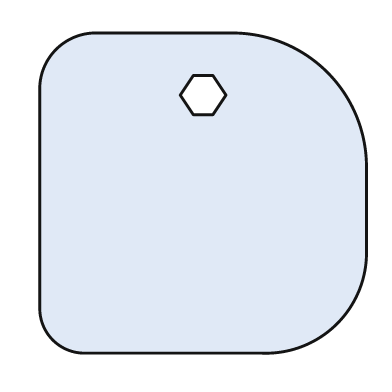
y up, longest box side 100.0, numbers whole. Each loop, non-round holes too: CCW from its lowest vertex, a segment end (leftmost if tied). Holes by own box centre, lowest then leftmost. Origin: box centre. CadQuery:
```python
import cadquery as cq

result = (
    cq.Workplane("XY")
    .moveTo(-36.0, -49.0)
    .lineTo(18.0, -49.0)
    .threePointArc((41.0, -40.0), (50.0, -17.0))
    .lineTo(50.0, 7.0)
    .threePointArc((38.0, 37.0), (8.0, 49.0))
    .lineTo(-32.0, 49.0)
    .threePointArc((-45.0, 44.0), (-50.0, 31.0))
    .lineTo(-50.0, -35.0)
    .threePointArc((-46.0, -45.0), (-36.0, -49.0))
    .close()
    .moveTo(-3.0, 24.0)
    .lineTo(3.0, 24.0)
    .lineTo(7.0, 30.0)
    .lineTo(3.0, 36.0)
    .lineTo(-3.0, 36.0)
    .lineTo(-7.0, 30.0)
    .close()
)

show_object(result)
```